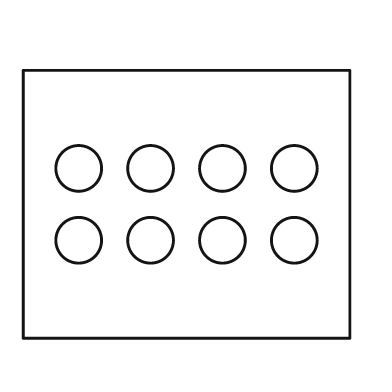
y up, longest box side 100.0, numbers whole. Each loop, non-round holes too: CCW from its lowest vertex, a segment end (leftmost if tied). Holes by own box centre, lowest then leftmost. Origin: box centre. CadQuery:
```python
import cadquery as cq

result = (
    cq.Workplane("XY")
    .moveTo(-50.0, -41.0)
    .lineTo(50.0, -41.0)
    .lineTo(50.0, 41.0)
    .lineTo(-50.0, 41.0)
    .close()
    .moveTo(-33.0, -11.0)
    .circle(7.0)
    .moveTo(-11.0, -11.0)
    .circle(7.0)
    .moveTo(11.0, -11.0)
    .circle(7.0)
    .moveTo(33.0, -11.0)
    .circle(7.0)
    .moveTo(-33.0, 11.0)
    .circle(7.0)
    .moveTo(-11.0, 11.0)
    .circle(7.0)
    .moveTo(11.0, 11.0)
    .circle(7.0)
    .moveTo(33.0, 11.0)
    .circle(7.0)
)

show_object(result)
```